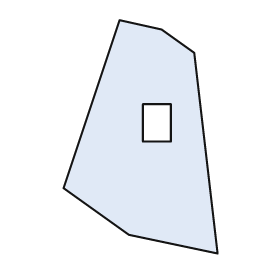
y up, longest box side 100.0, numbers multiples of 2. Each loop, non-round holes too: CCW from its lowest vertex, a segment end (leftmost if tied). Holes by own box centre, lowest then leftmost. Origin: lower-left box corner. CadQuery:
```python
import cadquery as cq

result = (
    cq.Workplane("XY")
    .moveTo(66.0, 0.0)
    .lineTo(56.0, 86.0)
    .lineTo(42.0, 96.0)
    .lineTo(24.0, 100.0)
    .lineTo(0.0, 28.0)
    .lineTo(28.0, 8.0)
    .close()
    .moveTo(34.0, 48.0)
    .lineTo(46.0, 48.0)
    .lineTo(46.0, 64.0)
    .lineTo(34.0, 64.0)
    .close()
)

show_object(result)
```